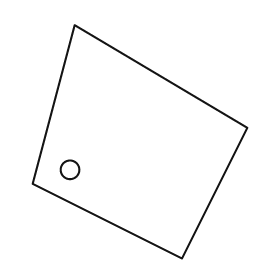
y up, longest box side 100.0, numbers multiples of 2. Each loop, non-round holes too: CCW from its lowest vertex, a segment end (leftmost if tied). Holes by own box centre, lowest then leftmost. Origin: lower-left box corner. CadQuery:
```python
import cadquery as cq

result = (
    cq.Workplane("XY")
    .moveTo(64.0, 0.0)
    .lineTo(92.0, 56.0)
    .lineTo(18.0, 100.0)
    .lineTo(0.0, 32.0)
    .close()
    .moveTo(16.0, 38.0)
    .circle(4.0)
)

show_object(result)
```